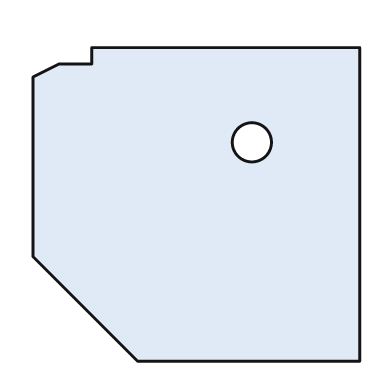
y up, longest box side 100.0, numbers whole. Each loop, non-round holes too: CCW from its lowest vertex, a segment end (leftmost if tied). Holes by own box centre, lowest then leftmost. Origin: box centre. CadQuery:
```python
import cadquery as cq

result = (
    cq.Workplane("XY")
    .moveTo(-18.0, -48.0)
    .lineTo(50.0, -48.0)
    .lineTo(50.0, 48.0)
    .lineTo(-32.0, 48.0)
    .lineTo(-32.0, 43.0)
    .lineTo(-42.0, 43.0)
    .lineTo(-50.0, 39.0)
    .lineTo(-50.0, -16.0)
    .close()
    .moveTo(17.0, 19.0)
    .circle(6.0)
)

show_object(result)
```